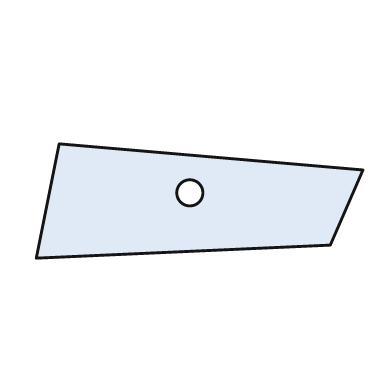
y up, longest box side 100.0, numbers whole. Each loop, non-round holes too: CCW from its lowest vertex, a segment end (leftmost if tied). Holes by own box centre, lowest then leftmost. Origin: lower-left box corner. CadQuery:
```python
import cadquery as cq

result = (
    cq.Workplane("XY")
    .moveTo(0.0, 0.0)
    .lineTo(90.0, 4.0)
    .lineTo(100.0, 27.0)
    .lineTo(7.0, 35.0)
    .close()
    .moveTo(47.0, 20.0)
    .circle(4.0)
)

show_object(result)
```